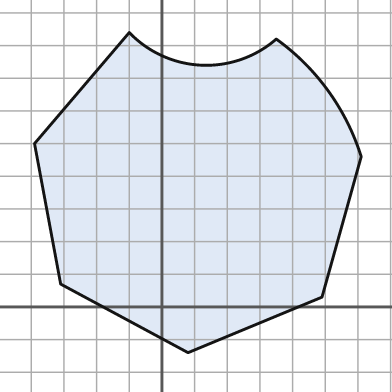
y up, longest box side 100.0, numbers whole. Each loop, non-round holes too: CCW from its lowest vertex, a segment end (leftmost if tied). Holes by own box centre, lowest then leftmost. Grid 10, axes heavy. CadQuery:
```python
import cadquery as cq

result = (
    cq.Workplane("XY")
    .moveTo(8.0, -14.0)
    .lineTo(49.0, 3.0)
    .lineTo(61.0, 46.0)
    .threePointArc((51.0, 66.0), (35.0, 82.0))
    .threePointArc((12.0, 74.0), (-10.0, 84.0))
    .lineTo(-39.0, 50.0)
    .lineTo(-31.0, 7.0)
    .close()
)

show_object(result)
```